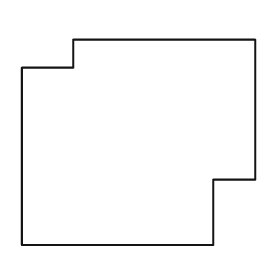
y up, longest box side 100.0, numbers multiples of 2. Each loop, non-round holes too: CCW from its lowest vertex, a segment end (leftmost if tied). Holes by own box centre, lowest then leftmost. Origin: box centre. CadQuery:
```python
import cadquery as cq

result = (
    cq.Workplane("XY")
    .moveTo(-50.0, -44.0)
    .lineTo(32.0, -44.0)
    .lineTo(32.0, -16.0)
    .lineTo(50.0, -16.0)
    .lineTo(50.0, 44.0)
    .lineTo(-28.0, 44.0)
    .lineTo(-28.0, 32.0)
    .lineTo(-50.0, 32.0)
    .close()
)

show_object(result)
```